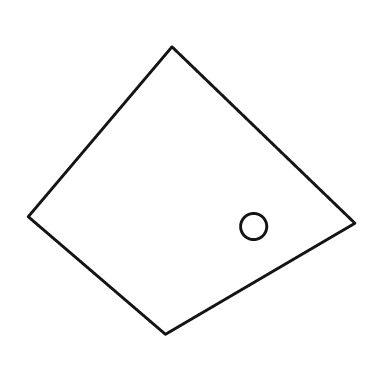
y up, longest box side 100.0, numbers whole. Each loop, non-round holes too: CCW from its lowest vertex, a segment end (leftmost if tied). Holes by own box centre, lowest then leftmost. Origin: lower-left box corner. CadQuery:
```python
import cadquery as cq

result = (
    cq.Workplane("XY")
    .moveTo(42.0, 0.0)
    .lineTo(100.0, 34.0)
    .lineTo(44.0, 88.0)
    .lineTo(0.0, 36.0)
    .close()
    .moveTo(69.0, 33.0)
    .circle(4.0)
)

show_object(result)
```